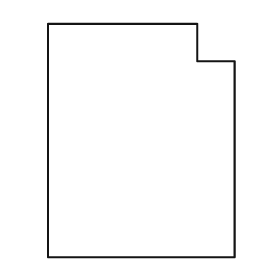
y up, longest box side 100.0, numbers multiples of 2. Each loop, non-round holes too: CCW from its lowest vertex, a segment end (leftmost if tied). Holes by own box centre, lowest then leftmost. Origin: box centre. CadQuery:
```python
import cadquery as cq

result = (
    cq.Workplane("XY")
    .moveTo(-40.0, -50.0)
    .lineTo(40.0, -50.0)
    .lineTo(40.0, 34.0)
    .lineTo(24.0, 34.0)
    .lineTo(24.0, 50.0)
    .lineTo(-40.0, 50.0)
    .close()
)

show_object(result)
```